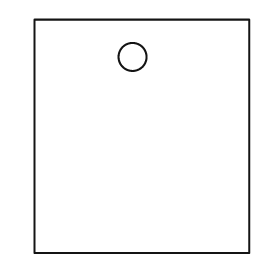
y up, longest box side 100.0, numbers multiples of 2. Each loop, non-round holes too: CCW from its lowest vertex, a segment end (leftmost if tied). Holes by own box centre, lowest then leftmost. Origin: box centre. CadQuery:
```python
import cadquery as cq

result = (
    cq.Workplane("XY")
    .moveTo(-46.0, -50.0)
    .lineTo(46.0, -50.0)
    .lineTo(46.0, 50.0)
    .lineTo(-46.0, 50.0)
    .close()
    .moveTo(-4.0, 34.0)
    .circle(6.0)
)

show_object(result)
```